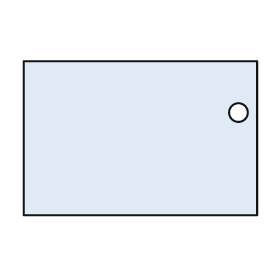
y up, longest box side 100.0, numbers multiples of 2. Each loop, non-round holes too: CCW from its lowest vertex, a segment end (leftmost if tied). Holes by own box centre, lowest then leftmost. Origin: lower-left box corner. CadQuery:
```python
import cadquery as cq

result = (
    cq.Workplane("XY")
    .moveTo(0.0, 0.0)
    .lineTo(100.0, 0.0)
    .lineTo(100.0, 66.0)
    .lineTo(0.0, 66.0)
    .close()
    .moveTo(92.0, 44.0)
    .circle(4.0)
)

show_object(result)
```